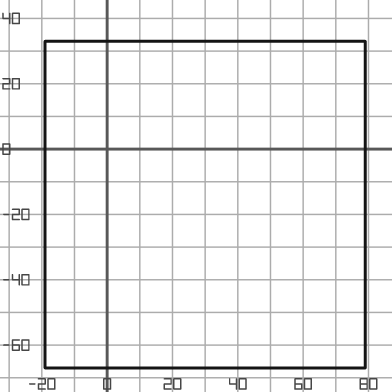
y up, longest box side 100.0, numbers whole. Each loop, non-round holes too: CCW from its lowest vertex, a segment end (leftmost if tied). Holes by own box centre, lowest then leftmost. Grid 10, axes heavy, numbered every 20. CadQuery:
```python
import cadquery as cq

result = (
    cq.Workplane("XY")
    .moveTo(-19.0, -67.0)
    .lineTo(79.0, -67.0)
    .lineTo(79.0, 33.0)
    .lineTo(-19.0, 33.0)
    .close()
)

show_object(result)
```